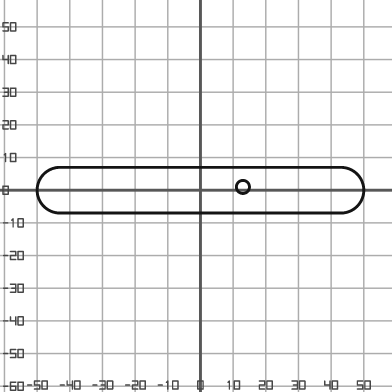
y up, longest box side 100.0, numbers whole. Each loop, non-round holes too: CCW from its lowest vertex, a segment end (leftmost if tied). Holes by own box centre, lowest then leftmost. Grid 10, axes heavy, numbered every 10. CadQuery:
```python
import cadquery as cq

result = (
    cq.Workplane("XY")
    .moveTo(-43.0, -7.0)
    .lineTo(43.0, -7.0)
    .threePointArc((50.0, 0.0), (43.0, 7.0))
    .lineTo(-43.0, 7.0)
    .threePointArc((-50.0, 0.0), (-43.0, -7.0))
    .close()
    .moveTo(13.0, 1.0)
    .circle(2.0)
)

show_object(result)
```